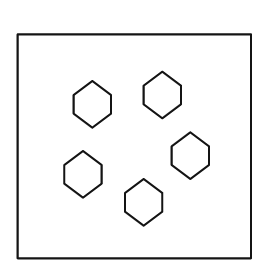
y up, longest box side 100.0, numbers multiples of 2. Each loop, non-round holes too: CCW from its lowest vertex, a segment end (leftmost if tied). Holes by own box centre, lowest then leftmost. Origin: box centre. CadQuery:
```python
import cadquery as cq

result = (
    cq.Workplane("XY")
    .moveTo(-50.0, -48.0)
    .lineTo(50.0, -48.0)
    .lineTo(50.0, 48.0)
    .lineTo(-50.0, 48.0)
    .close()
    .moveTo(4.0, -34.0)
    .lineTo(12.0, -28.0)
    .lineTo(12.0, -20.0)
    .lineTo(4.0, -14.0)
    .lineTo(-4.0, -20.0)
    .lineTo(-4.0, -28.0)
    .close()
    .moveTo(-22.0, -22.0)
    .lineTo(-14.0, -16.0)
    .lineTo(-14.0, -8.0)
    .lineTo(-22.0, -2.0)
    .lineTo(-30.0, -8.0)
    .lineTo(-30.0, -16.0)
    .close()
    .moveTo(24.0, -14.0)
    .lineTo(32.0, -8.0)
    .lineTo(32.0, 0.0)
    .lineTo(24.0, 6.0)
    .lineTo(16.0, 0.0)
    .lineTo(16.0, -8.0)
    .close()
    .moveTo(-18.0, 8.0)
    .lineTo(-10.0, 14.0)
    .lineTo(-10.0, 22.0)
    .lineTo(-18.0, 28.0)
    .lineTo(-26.0, 22.0)
    .lineTo(-26.0, 14.0)
    .close()
    .moveTo(12.0, 12.0)
    .lineTo(20.0, 18.0)
    .lineTo(20.0, 26.0)
    .lineTo(12.0, 32.0)
    .lineTo(4.0, 26.0)
    .lineTo(4.0, 18.0)
    .close()
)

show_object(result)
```